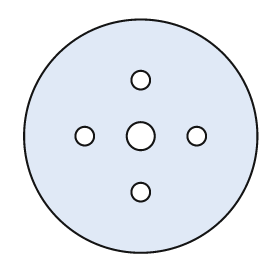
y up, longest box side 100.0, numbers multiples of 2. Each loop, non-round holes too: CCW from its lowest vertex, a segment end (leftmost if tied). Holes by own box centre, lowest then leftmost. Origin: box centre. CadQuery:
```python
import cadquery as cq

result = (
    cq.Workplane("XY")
    .moveTo(0.0, 0.0)
    .circle(50.0)
    .moveTo(0.0, -24.0)
    .circle(4.0)
    .moveTo(-24.0, 0.0)
    .circle(4.0)
    .moveTo(0.0, 0.0)
    .circle(6.0)
    .moveTo(24.0, 0.0)
    .circle(4.0)
    .moveTo(0.0, 24.0)
    .circle(4.0)
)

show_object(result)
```